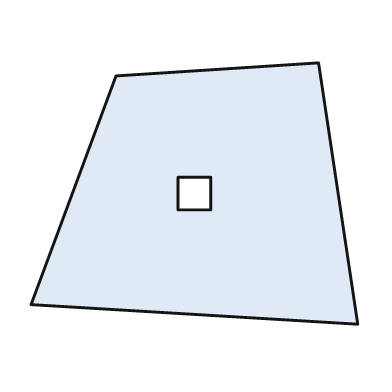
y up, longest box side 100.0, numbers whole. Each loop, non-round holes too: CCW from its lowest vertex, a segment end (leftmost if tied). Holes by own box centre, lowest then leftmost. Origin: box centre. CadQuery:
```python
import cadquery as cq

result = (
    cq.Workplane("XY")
    .moveTo(50.0, -40.0)
    .lineTo(38.0, 40.0)
    .lineTo(-24.0, 36.0)
    .lineTo(-50.0, -34.0)
    .close()
    .moveTo(-5.0, -5.0)
    .lineTo(5.0, -5.0)
    .lineTo(5.0, 5.0)
    .lineTo(-5.0, 5.0)
    .close()
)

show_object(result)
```